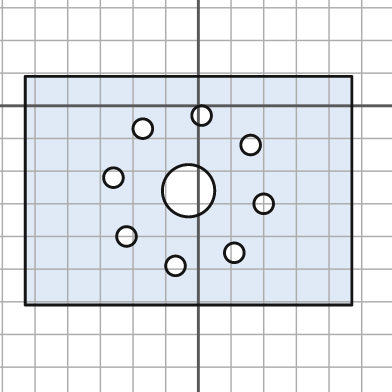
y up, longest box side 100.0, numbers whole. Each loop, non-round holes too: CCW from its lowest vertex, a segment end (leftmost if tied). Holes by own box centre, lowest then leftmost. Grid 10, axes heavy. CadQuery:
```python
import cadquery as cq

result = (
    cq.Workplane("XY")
    .moveTo(-53.0, -61.0)
    .lineTo(47.0, -61.0)
    .lineTo(47.0, 9.0)
    .lineTo(-53.0, 9.0)
    .close()
    .moveTo(-7.0, -49.0)
    .circle(3.0)
    .moveTo(11.0, -45.0)
    .circle(3.0)
    .moveTo(-22.0, -40.0)
    .circle(3.0)
    .moveTo(20.0, -30.0)
    .circle(3.0)
    .moveTo(-3.0, -26.0)
    .circle(8.0)
    .moveTo(-26.0, -22.0)
    .circle(3.0)
    .moveTo(16.0, -12.0)
    .circle(3.0)
    .moveTo(-17.0, -7.0)
    .circle(3.0)
    .moveTo(1.0, -3.0)
    .circle(3.0)
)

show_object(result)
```